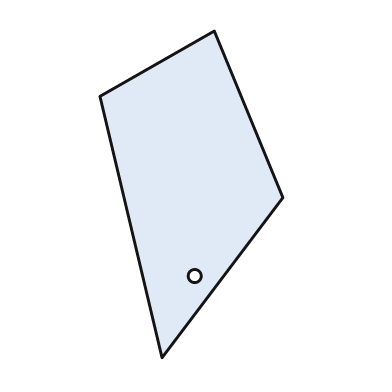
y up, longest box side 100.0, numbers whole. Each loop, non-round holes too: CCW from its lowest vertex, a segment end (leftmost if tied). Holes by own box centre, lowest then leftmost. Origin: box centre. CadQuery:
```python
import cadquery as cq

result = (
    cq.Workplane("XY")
    .moveTo(-9.0, -50.0)
    .lineTo(28.0, -1.0)
    .lineTo(7.0, 50.0)
    .lineTo(-28.0, 30.0)
    .close()
    .moveTo(1.0, -25.0)
    .circle(2.0)
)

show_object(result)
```